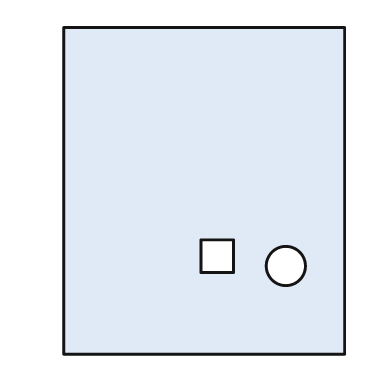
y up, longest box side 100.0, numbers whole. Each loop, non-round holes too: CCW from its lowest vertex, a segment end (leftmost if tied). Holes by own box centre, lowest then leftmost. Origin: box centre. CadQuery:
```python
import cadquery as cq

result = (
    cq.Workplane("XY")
    .moveTo(-43.0, -50.0)
    .lineTo(43.0, -50.0)
    .lineTo(43.0, 50.0)
    .lineTo(-43.0, 50.0)
    .close()
    .moveTo(25.0, -23.0)
    .circle(6.0)
    .moveTo(-1.0, -25.0)
    .lineTo(9.0, -25.0)
    .lineTo(9.0, -15.0)
    .lineTo(-1.0, -15.0)
    .close()
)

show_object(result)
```